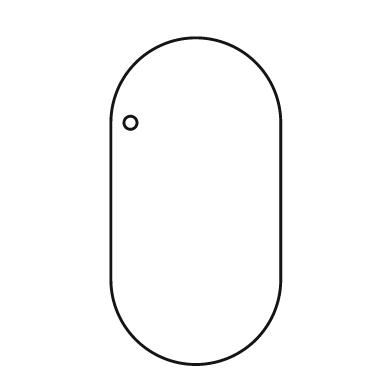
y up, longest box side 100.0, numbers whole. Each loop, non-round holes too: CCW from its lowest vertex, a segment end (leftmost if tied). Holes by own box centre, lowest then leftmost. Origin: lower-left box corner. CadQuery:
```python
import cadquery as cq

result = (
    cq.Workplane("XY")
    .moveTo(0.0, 26.0)
    .threePointArc((26.0, 0.0), (52.0, 26.0))
    .lineTo(52.0, 74.0)
    .threePointArc((26.0, 100.0), (0.0, 74.0))
    .close()
    .moveTo(6.0, 74.0)
    .circle(2.0)
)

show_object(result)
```